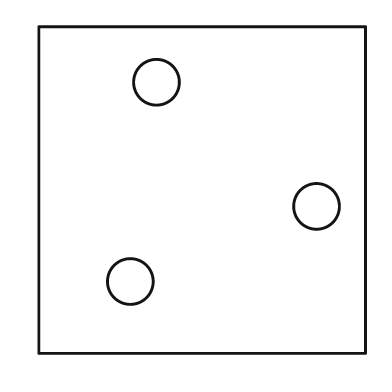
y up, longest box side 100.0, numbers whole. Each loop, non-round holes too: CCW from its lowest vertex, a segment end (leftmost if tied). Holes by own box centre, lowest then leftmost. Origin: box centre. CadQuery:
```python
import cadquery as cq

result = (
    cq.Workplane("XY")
    .moveTo(-50.0, -50.0)
    .lineTo(50.0, -50.0)
    .lineTo(50.0, 50.0)
    .lineTo(-50.0, 50.0)
    .close()
    .moveTo(-22.0, -28.0)
    .circle(7.0)
    .moveTo(35.0, -5.0)
    .circle(7.0)
    .moveTo(-14.0, 33.0)
    .circle(7.0)
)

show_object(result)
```